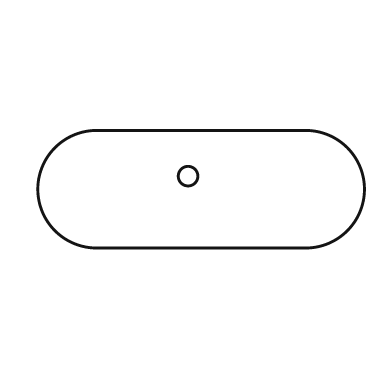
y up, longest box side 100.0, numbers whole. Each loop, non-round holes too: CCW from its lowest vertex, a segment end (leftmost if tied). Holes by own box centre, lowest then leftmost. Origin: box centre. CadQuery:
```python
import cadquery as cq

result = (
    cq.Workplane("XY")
    .moveTo(-32.0, -18.0)
    .lineTo(32.0, -18.0)
    .threePointArc((50.0, 0.0), (32.0, 18.0))
    .lineTo(-32.0, 18.0)
    .threePointArc((-50.0, 0.0), (-32.0, -18.0))
    .close()
    .moveTo(-4.0, 4.0)
    .circle(3.0)
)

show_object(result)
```